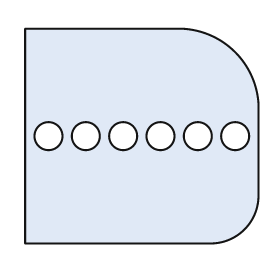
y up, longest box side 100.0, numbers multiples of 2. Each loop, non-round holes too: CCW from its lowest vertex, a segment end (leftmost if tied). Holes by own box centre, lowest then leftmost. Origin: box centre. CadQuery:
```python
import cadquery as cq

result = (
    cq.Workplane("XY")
    .moveTo(-50.0, -46.0)
    .lineTo(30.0, -46.0)
    .threePointArc((44.0, -40.0), (50.0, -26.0))
    .lineTo(50.0, 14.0)
    .threePointArc((40.0, 36.0), (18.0, 46.0))
    .lineTo(-50.0, 46.0)
    .close()
    .moveTo(-40.0, 0.0)
    .circle(6.0)
    .moveTo(-24.0, 0.0)
    .circle(6.0)
    .moveTo(-8.0, 0.0)
    .circle(6.0)
    .moveTo(8.0, 0.0)
    .circle(6.0)
    .moveTo(24.0, 0.0)
    .circle(6.0)
    .moveTo(40.0, 0.0)
    .circle(6.0)
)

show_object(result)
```